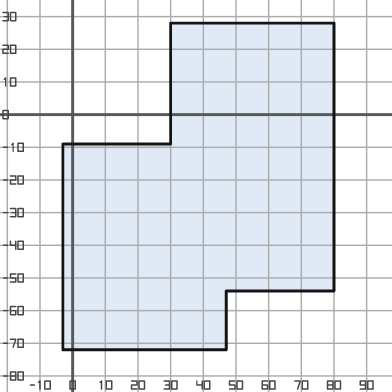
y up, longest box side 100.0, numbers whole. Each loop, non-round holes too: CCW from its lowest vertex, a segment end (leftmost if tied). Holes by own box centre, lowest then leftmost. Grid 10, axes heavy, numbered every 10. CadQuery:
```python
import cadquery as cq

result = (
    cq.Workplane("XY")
    .moveTo(-3.0, -72.0)
    .lineTo(47.0, -72.0)
    .lineTo(47.0, -54.0)
    .lineTo(80.0, -54.0)
    .lineTo(80.0, 28.0)
    .lineTo(30.0, 28.0)
    .lineTo(30.0, -9.0)
    .lineTo(-3.0, -9.0)
    .close()
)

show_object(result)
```